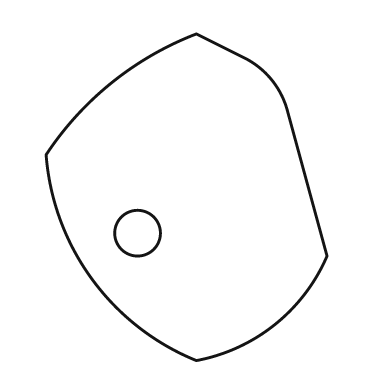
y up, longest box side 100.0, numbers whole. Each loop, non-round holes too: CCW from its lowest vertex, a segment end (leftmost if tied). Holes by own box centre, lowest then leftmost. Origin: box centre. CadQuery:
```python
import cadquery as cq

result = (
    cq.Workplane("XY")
    .moveTo(3.0, -50.0)
    .threePointArc((27.0, -39.0), (43.0, -18.0))
    .lineTo(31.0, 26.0)
    .threePointArc((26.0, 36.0), (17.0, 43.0))
    .lineTo(3.0, 50.0)
    .threePointArc((-23.0, 35.0), (-43.0, 13.0))
    .threePointArc((-29.0, -25.0), (3.0, -50.0))
    .close()
    .moveTo(-15.0, -11.0)
    .circle(7.0)
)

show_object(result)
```